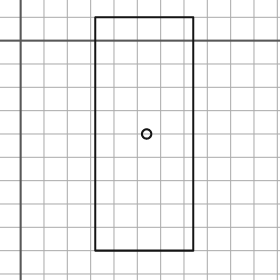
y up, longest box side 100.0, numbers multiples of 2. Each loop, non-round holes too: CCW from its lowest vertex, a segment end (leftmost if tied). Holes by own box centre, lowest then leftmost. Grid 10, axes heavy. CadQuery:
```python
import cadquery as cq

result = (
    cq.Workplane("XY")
    .moveTo(32.0, -90.0)
    .lineTo(74.0, -90.0)
    .lineTo(74.0, 10.0)
    .lineTo(32.0, 10.0)
    .close()
    .moveTo(54.0, -40.0)
    .circle(2.0)
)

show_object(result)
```